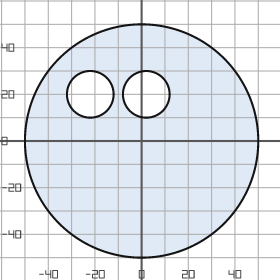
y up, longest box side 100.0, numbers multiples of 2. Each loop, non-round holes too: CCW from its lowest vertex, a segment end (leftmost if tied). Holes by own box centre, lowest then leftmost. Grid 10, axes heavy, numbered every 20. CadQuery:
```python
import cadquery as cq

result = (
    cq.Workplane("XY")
    .moveTo(0.0, 0.0)
    .circle(50.0)
    .moveTo(-22.0, 20.0)
    .circle(10.0)
    .moveTo(2.0, 20.0)
    .circle(10.0)
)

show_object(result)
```